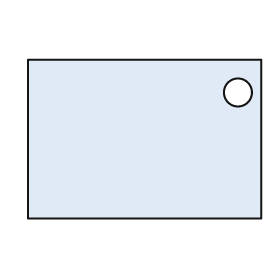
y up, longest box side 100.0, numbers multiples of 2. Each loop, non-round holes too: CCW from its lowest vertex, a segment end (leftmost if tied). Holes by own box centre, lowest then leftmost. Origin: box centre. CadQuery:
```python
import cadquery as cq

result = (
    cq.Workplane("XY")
    .moveTo(-50.0, -34.0)
    .lineTo(50.0, -34.0)
    .lineTo(50.0, 34.0)
    .lineTo(-50.0, 34.0)
    .close()
    .moveTo(40.0, 20.0)
    .circle(6.0)
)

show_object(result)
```